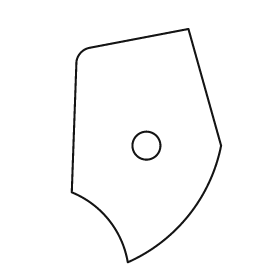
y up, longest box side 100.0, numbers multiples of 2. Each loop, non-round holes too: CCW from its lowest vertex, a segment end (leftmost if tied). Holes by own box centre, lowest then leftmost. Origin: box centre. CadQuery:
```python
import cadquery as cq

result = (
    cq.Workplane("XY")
    .moveTo(-8.0, -50.0)
    .threePointArc((18.0, -30.0), (32.0, 0.0))
    .lineTo(18.0, 50.0)
    .lineTo(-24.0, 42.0)
    .threePointArc((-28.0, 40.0), (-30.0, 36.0))
    .lineTo(-32.0, -20.0)
    .threePointArc((-16.0, -32.0), (-8.0, -50.0))
    .close()
    .moveTo(0.0, 0.0)
    .circle(6.0)
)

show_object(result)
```